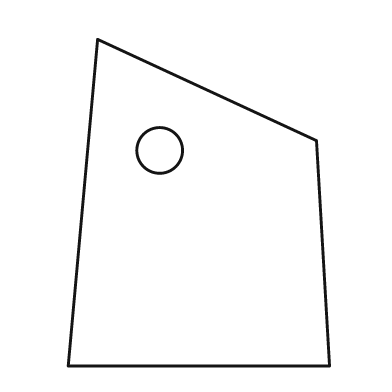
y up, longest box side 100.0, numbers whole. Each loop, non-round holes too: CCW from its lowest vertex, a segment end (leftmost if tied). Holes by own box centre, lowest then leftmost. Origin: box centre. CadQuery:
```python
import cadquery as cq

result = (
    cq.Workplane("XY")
    .moveTo(-40.0, -50.0)
    .lineTo(40.0, -50.0)
    .lineTo(36.0, 19.0)
    .lineTo(-31.0, 50.0)
    .close()
    .moveTo(-12.0, 16.0)
    .circle(7.0)
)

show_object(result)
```